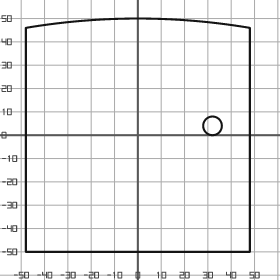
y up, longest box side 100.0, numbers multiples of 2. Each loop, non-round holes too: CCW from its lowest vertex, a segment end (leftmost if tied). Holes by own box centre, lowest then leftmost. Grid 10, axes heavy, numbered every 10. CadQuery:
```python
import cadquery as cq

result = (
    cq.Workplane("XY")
    .moveTo(-48.0, -50.0)
    .lineTo(48.0, -50.0)
    .lineTo(48.0, 46.0)
    .threePointArc((0.0, 50.0), (-48.0, 46.0))
    .close()
    .moveTo(32.0, 4.0)
    .circle(4.0)
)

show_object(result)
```